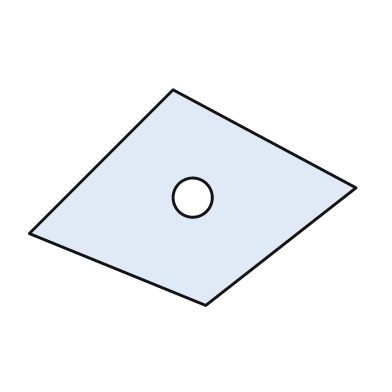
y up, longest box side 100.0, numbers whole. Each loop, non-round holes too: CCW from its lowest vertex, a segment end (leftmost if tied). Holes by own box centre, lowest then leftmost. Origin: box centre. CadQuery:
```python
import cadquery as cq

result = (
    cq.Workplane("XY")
    .moveTo(4.0, -33.0)
    .lineTo(50.0, 3.0)
    .lineTo(-6.0, 33.0)
    .lineTo(-50.0, -11.0)
    .close()
    .moveTo(0.0, 0.0)
    .circle(6.0)
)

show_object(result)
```